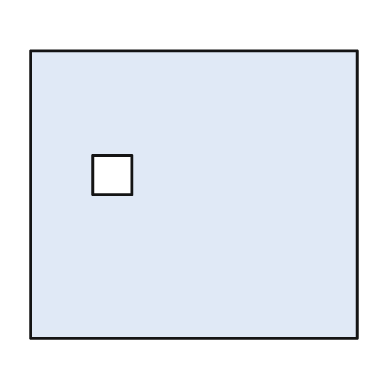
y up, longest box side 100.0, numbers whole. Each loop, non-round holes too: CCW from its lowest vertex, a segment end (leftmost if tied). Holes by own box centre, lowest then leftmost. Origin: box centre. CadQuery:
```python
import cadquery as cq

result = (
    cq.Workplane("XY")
    .moveTo(-50.0, -44.0)
    .lineTo(50.0, -44.0)
    .lineTo(50.0, 44.0)
    .lineTo(-50.0, 44.0)
    .close()
    .moveTo(-31.0, 0.0)
    .lineTo(-19.0, 0.0)
    .lineTo(-19.0, 12.0)
    .lineTo(-31.0, 12.0)
    .close()
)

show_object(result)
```